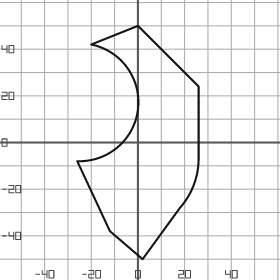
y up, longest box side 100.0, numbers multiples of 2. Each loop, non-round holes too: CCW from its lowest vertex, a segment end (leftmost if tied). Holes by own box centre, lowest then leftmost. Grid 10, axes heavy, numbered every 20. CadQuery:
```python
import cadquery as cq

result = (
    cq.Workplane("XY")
    .moveTo(2.0, -50.0)
    .lineTo(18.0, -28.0)
    .threePointArc((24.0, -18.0), (26.0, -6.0))
    .lineTo(26.0, 24.0)
    .lineTo(0.0, 50.0)
    .lineTo(-20.0, 42.0)
    .threePointArc((0.0, 14.0), (-26.0, -8.0))
    .lineTo(-12.0, -38.0)
    .close()
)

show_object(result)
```